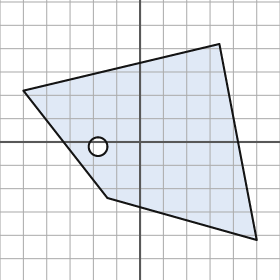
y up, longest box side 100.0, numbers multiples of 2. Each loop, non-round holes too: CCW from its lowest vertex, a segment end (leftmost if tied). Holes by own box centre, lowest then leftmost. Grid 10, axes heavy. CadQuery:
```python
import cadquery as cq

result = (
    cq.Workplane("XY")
    .moveTo(50.0, -42.0)
    .lineTo(34.0, 42.0)
    .lineTo(-50.0, 22.0)
    .lineTo(-14.0, -24.0)
    .close()
    .moveTo(-18.0, -2.0)
    .circle(4.0)
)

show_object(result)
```